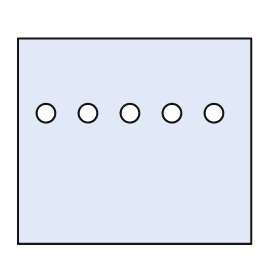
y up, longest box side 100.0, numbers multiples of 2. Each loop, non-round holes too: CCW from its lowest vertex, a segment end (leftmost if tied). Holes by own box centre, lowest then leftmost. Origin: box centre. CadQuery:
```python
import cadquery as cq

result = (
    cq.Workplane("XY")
    .moveTo(-50.0, -44.0)
    .lineTo(50.0, -44.0)
    .lineTo(50.0, 44.0)
    .lineTo(-50.0, 44.0)
    .close()
    .moveTo(-38.0, 12.0)
    .circle(4.0)
    .moveTo(-20.0, 12.0)
    .circle(4.0)
    .moveTo(-2.0, 12.0)
    .circle(4.0)
    .moveTo(16.0, 12.0)
    .circle(4.0)
    .moveTo(34.0, 12.0)
    .circle(4.0)
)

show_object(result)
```